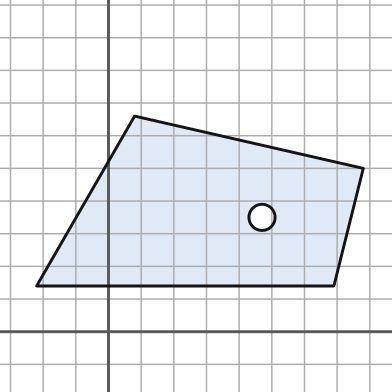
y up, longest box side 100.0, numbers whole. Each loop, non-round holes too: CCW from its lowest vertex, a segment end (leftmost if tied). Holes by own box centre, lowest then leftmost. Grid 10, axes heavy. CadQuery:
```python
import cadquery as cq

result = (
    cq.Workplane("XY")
    .moveTo(-22.0, 14.0)
    .lineTo(69.0, 14.0)
    .lineTo(78.0, 50.0)
    .lineTo(8.0, 66.0)
    .close()
    .moveTo(47.0, 35.0)
    .circle(4.0)
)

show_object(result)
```